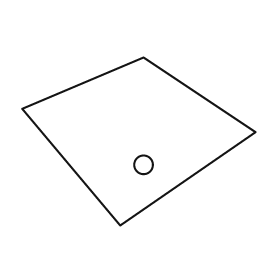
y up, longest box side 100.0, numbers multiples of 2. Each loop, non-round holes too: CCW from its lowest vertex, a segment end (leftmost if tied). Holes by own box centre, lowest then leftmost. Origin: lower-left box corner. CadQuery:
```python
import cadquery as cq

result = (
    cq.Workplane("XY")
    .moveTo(42.0, 0.0)
    .lineTo(100.0, 40.0)
    .lineTo(52.0, 72.0)
    .lineTo(0.0, 50.0)
    .close()
    .moveTo(52.0, 26.0)
    .circle(4.0)
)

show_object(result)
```